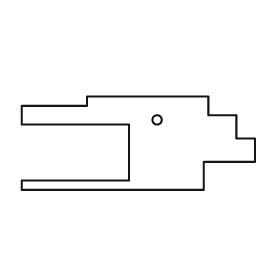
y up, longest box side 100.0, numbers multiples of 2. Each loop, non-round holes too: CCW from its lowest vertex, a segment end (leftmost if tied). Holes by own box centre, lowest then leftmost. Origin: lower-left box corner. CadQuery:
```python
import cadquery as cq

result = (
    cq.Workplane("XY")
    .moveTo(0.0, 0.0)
    .lineTo(78.0, 0.0)
    .lineTo(78.0, 12.0)
    .lineTo(100.0, 12.0)
    .lineTo(100.0, 22.0)
    .lineTo(92.0, 22.0)
    .lineTo(92.0, 32.0)
    .lineTo(80.0, 32.0)
    .lineTo(80.0, 40.0)
    .lineTo(28.0, 40.0)
    .lineTo(28.0, 36.0)
    .lineTo(0.0, 36.0)
    .lineTo(0.0, 28.0)
    .lineTo(46.0, 28.0)
    .lineTo(46.0, 4.0)
    .lineTo(0.0, 4.0)
    .close()
    .moveTo(58.0, 30.0)
    .circle(2.0)
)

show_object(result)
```